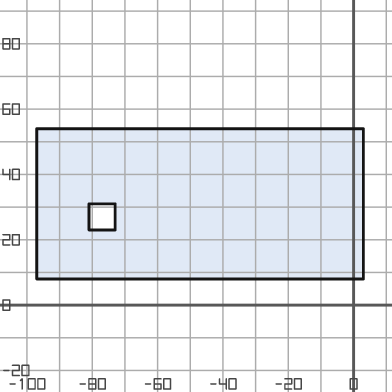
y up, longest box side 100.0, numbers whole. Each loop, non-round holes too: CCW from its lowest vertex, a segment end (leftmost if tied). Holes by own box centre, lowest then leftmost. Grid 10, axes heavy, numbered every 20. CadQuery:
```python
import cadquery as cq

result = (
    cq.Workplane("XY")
    .moveTo(-97.0, 8.0)
    .lineTo(3.0, 8.0)
    .lineTo(3.0, 54.0)
    .lineTo(-97.0, 54.0)
    .close()
    .moveTo(-81.0, 23.0)
    .lineTo(-73.0, 23.0)
    .lineTo(-73.0, 31.0)
    .lineTo(-81.0, 31.0)
    .close()
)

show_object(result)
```